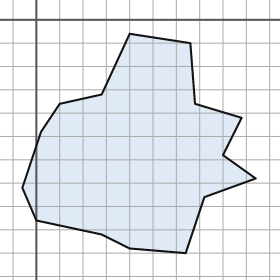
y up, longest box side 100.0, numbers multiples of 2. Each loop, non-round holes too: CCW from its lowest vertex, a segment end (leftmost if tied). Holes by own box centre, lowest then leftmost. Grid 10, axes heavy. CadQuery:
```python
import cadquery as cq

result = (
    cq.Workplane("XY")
    .moveTo(64.0, -100.0)
    .lineTo(72.0, -76.0)
    .lineTo(94.0, -68.0)
    .lineTo(80.0, -58.0)
    .lineTo(88.0, -42.0)
    .lineTo(68.0, -36.0)
    .lineTo(66.0, -10.0)
    .lineTo(40.0, -6.0)
    .lineTo(28.0, -32.0)
    .lineTo(10.0, -36.0)
    .lineTo(2.0, -48.0)
    .lineTo(-6.0, -72.0)
    .lineTo(0.0, -86.0)
    .lineTo(28.0, -92.0)
    .lineTo(40.0, -98.0)
    .close()
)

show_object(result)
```